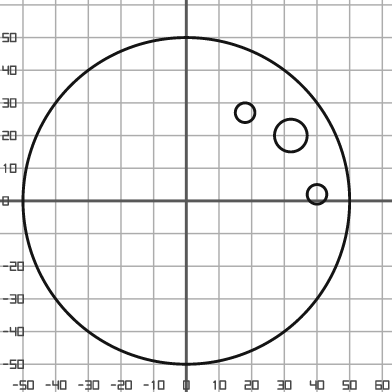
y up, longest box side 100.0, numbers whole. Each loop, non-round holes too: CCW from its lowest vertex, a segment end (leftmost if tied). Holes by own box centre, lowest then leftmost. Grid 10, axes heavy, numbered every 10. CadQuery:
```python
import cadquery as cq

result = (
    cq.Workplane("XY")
    .moveTo(0.0, 0.0)
    .circle(50.0)
    .moveTo(40.0, 2.0)
    .circle(3.0)
    .moveTo(32.0, 20.0)
    .circle(5.0)
    .moveTo(18.0, 27.0)
    .circle(3.0)
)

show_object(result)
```